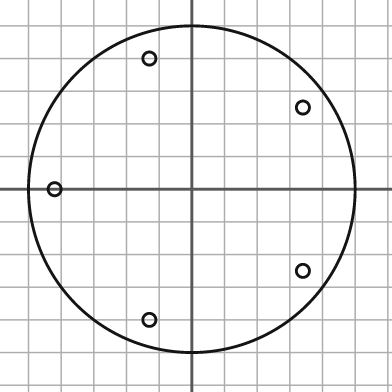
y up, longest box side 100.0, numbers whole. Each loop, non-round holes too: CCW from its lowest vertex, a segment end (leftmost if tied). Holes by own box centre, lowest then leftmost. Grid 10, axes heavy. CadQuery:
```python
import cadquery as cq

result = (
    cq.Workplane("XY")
    .moveTo(0.0, 0.0)
    .circle(50.0)
    .moveTo(-13.0, -40.0)
    .circle(2.0)
    .moveTo(34.0, -25.0)
    .circle(2.0)
    .moveTo(-42.0, 0.0)
    .circle(2.0)
    .moveTo(34.0, 25.0)
    .circle(2.0)
    .moveTo(-13.0, 40.0)
    .circle(2.0)
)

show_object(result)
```